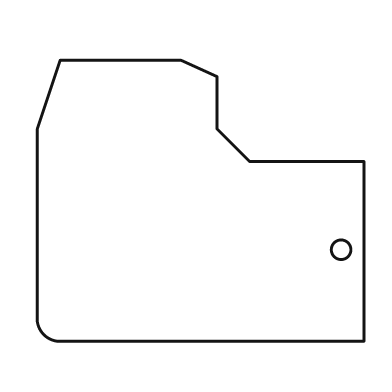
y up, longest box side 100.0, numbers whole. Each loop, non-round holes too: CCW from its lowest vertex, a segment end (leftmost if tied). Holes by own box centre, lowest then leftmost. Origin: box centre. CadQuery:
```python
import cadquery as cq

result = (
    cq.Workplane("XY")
    .moveTo(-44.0, -43.0)
    .lineTo(50.0, -43.0)
    .lineTo(50.0, 12.0)
    .lineTo(15.0, 12.0)
    .lineTo(5.0, 22.0)
    .lineTo(5.0, 38.0)
    .lineTo(-6.0, 43.0)
    .lineTo(-43.0, 43.0)
    .lineTo(-50.0, 22.0)
    .lineTo(-50.0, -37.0)
    .threePointArc((-48.0, -41.0), (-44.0, -43.0))
    .close()
    .moveTo(43.0, -15.0)
    .circle(3.0)
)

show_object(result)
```